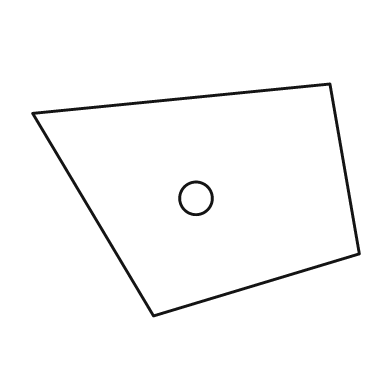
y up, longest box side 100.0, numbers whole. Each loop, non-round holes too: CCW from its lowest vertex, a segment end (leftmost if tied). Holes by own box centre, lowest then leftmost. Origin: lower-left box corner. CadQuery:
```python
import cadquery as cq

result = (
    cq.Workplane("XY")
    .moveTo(37.0, 0.0)
    .lineTo(100.0, 19.0)
    .lineTo(91.0, 71.0)
    .lineTo(0.0, 62.0)
    .close()
    .moveTo(50.0, 36.0)
    .circle(5.0)
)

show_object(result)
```